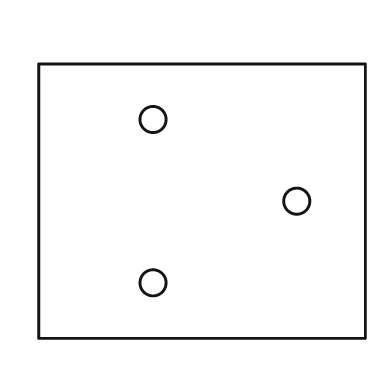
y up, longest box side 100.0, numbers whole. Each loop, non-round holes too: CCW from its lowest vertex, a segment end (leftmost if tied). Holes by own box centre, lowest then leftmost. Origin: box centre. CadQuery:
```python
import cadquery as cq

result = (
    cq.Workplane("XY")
    .moveTo(-50.0, -42.0)
    .lineTo(50.0, -42.0)
    .lineTo(50.0, 42.0)
    .lineTo(-50.0, 42.0)
    .close()
    .moveTo(-15.0, -25.0)
    .circle(4.0)
    .moveTo(29.0, 0.0)
    .circle(4.0)
    .moveTo(-15.0, 25.0)
    .circle(4.0)
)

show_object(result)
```